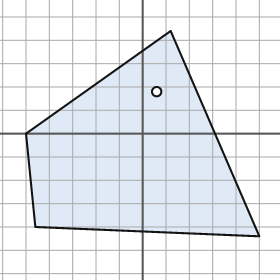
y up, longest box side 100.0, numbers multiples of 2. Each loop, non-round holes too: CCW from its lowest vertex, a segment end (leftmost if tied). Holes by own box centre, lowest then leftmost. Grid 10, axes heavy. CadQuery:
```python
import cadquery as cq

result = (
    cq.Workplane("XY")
    .moveTo(50.0, -44.0)
    .lineTo(12.0, 44.0)
    .lineTo(-50.0, 0.0)
    .lineTo(-46.0, -40.0)
    .close()
    .moveTo(6.0, 18.0)
    .circle(2.0)
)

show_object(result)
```